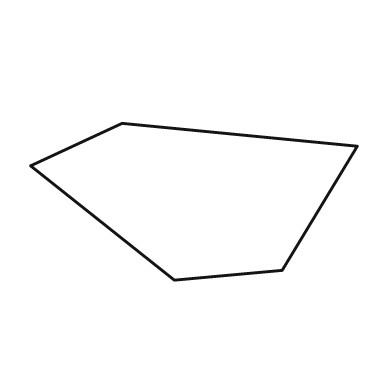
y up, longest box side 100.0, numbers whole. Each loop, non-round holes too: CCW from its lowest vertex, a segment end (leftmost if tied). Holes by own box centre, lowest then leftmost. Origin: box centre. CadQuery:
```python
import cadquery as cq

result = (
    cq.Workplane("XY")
    .moveTo(-6.0, -24.0)
    .lineTo(27.0, -21.0)
    .lineTo(50.0, 17.0)
    .lineTo(-22.0, 24.0)
    .lineTo(-50.0, 11.0)
    .close()
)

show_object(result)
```